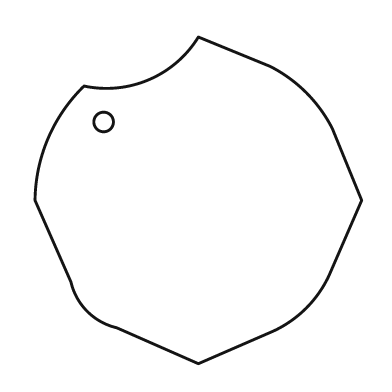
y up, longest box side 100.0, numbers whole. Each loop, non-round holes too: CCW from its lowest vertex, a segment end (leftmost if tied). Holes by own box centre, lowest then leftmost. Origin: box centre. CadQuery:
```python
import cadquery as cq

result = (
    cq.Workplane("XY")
    .moveTo(0.0, -50.0)
    .lineTo(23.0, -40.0)
    .threePointArc((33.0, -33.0), (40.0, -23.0))
    .lineTo(50.0, 0.0)
    .lineTo(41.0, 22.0)
    .threePointArc((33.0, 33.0), (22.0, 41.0))
    .lineTo(0.0, 50.0)
    .threePointArc((-15.0, 37.0), (-35.0, 35.0))
    .threePointArc((-46.0, 19.0), (-50.0, 0.0))
    .lineTo(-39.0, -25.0)
    .threePointArc((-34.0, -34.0), (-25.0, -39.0))
    .close()
    .moveTo(-29.0, 24.0)
    .circle(3.0)
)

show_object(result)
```